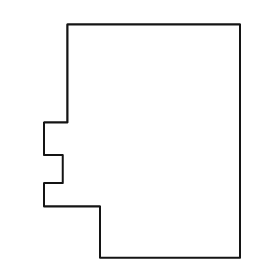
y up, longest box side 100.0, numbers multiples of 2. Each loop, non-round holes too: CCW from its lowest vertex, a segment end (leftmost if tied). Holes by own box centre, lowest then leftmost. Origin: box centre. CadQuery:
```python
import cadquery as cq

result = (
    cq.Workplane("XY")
    .moveTo(-18.0, -50.0)
    .lineTo(42.0, -50.0)
    .lineTo(42.0, 50.0)
    .lineTo(-32.0, 50.0)
    .lineTo(-32.0, 8.0)
    .lineTo(-42.0, 8.0)
    .lineTo(-42.0, -6.0)
    .lineTo(-34.0, -6.0)
    .lineTo(-34.0, -18.0)
    .lineTo(-42.0, -18.0)
    .lineTo(-42.0, -28.0)
    .lineTo(-18.0, -28.0)
    .close()
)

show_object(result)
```